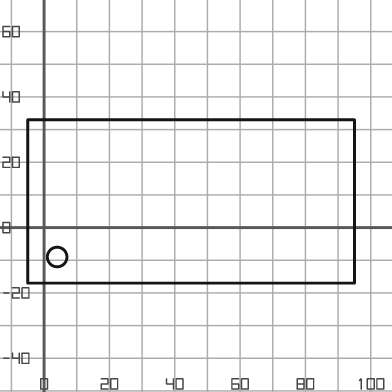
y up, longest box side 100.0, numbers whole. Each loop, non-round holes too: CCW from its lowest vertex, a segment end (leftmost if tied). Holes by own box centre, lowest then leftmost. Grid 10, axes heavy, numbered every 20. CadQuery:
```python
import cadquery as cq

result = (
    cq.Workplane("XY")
    .moveTo(-5.0, -17.0)
    .lineTo(95.0, -17.0)
    .lineTo(95.0, 33.0)
    .lineTo(-5.0, 33.0)
    .close()
    .moveTo(4.0, -9.0)
    .circle(3.0)
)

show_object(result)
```